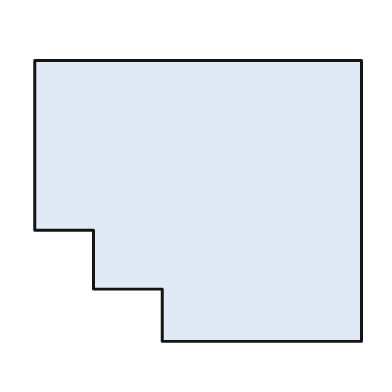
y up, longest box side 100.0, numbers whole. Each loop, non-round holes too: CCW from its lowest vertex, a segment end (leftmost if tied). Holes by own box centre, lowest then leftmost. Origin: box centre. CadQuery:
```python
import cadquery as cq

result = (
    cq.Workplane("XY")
    .moveTo(-11.0, -43.0)
    .lineTo(50.0, -43.0)
    .lineTo(50.0, 43.0)
    .lineTo(-50.0, 43.0)
    .lineTo(-50.0, -9.0)
    .lineTo(-32.0, -9.0)
    .lineTo(-32.0, -27.0)
    .lineTo(-11.0, -27.0)
    .close()
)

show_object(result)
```